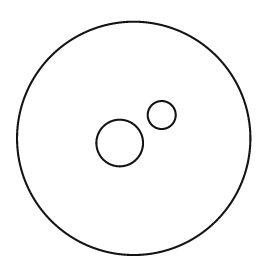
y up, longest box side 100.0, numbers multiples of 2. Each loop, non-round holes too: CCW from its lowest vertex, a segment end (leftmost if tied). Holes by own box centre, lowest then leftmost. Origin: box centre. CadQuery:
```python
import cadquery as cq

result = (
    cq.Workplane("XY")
    .moveTo(0.0, 0.0)
    .circle(50.0)
    .moveTo(-6.0, -2.0)
    .circle(10.0)
    .moveTo(12.0, 10.0)
    .circle(6.0)
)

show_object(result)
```